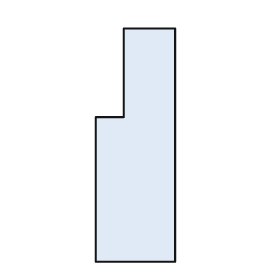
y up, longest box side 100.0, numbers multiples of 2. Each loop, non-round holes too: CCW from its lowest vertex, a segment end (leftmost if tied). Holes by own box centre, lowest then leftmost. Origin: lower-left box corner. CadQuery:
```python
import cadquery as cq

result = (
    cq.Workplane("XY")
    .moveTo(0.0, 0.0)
    .lineTo(34.0, 0.0)
    .lineTo(34.0, 100.0)
    .lineTo(12.0, 100.0)
    .lineTo(12.0, 62.0)
    .lineTo(0.0, 62.0)
    .close()
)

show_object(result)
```